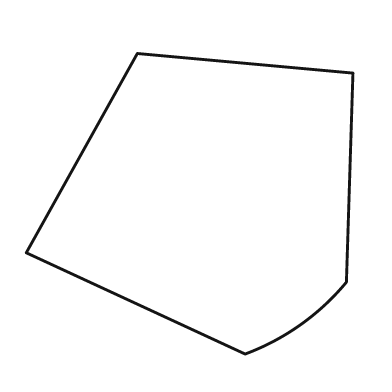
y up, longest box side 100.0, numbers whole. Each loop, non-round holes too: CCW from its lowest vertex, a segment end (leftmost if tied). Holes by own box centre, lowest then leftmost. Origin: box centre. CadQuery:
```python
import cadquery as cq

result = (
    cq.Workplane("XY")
    .moveTo(17.0, -46.0)
    .threePointArc((34.0, -37.0), (48.0, -24.0))
    .lineTo(50.0, 40.0)
    .lineTo(-16.0, 46.0)
    .lineTo(-50.0, -15.0)
    .close()
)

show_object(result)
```